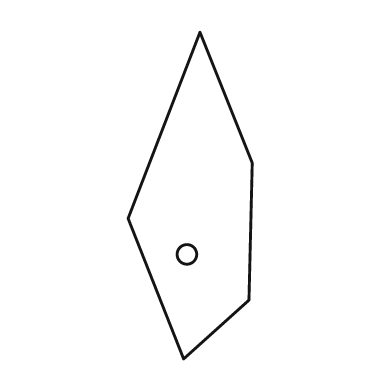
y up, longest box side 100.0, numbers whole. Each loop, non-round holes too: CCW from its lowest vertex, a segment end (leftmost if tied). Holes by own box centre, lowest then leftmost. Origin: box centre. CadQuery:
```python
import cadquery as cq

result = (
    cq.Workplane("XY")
    .moveTo(-2.0, -50.0)
    .lineTo(18.0, -32.0)
    .lineTo(19.0, 10.0)
    .lineTo(3.0, 50.0)
    .lineTo(-19.0, -7.0)
    .close()
    .moveTo(-1.0, -18.0)
    .circle(3.0)
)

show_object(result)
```